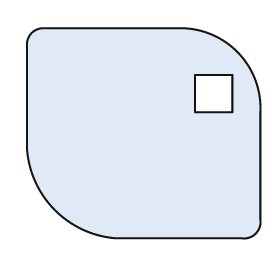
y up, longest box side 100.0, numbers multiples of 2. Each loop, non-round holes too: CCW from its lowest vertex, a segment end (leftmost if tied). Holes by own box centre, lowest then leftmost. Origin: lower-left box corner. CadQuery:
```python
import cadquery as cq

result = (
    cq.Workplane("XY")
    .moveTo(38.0, 0.0)
    .lineTo(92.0, 0.0)
    .threePointArc((98.0, 2.0), (100.0, 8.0))
    .lineTo(100.0, 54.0)
    .threePointArc((90.0, 80.0), (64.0, 90.0))
    .lineTo(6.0, 90.0)
    .threePointArc((2.0, 88.0), (0.0, 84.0))
    .lineTo(0.0, 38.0)
    .threePointArc((12.0, 12.0), (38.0, 0.0))
    .close()
    .moveTo(72.0, 54.0)
    .lineTo(88.0, 54.0)
    .lineTo(88.0, 70.0)
    .lineTo(72.0, 70.0)
    .close()
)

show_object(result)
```